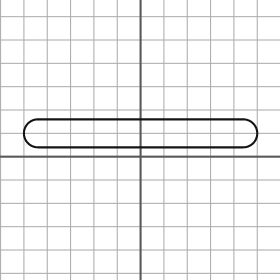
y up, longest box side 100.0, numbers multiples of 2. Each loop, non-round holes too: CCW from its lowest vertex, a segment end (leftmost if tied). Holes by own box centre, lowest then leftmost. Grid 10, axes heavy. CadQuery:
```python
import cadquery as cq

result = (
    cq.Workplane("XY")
    .moveTo(-44.0, 4.0)
    .lineTo(44.0, 4.0)
    .threePointArc((50.0, 10.0), (44.0, 16.0))
    .lineTo(-44.0, 16.0)
    .threePointArc((-50.0, 10.0), (-44.0, 4.0))
    .close()
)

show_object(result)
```